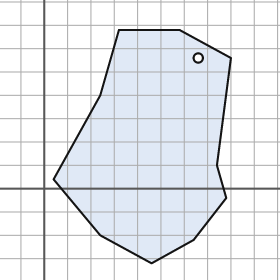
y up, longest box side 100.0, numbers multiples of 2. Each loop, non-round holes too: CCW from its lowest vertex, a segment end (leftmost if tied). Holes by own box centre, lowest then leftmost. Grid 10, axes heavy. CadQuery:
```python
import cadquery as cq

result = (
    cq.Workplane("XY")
    .moveTo(46.0, -32.0)
    .lineTo(64.0, -22.0)
    .lineTo(78.0, -4.0)
    .lineTo(74.0, 10.0)
    .lineTo(80.0, 56.0)
    .lineTo(58.0, 68.0)
    .lineTo(32.0, 68.0)
    .lineTo(24.0, 40.0)
    .lineTo(4.0, 4.0)
    .lineTo(24.0, -20.0)
    .close()
    .moveTo(66.0, 56.0)
    .circle(2.0)
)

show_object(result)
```